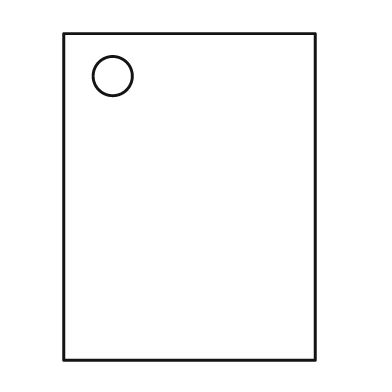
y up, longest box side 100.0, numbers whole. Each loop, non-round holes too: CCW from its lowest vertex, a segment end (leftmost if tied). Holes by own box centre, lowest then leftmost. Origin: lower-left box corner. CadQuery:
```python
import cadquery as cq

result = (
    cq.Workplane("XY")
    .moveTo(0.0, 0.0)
    .lineTo(77.0, 0.0)
    .lineTo(77.0, 100.0)
    .lineTo(0.0, 100.0)
    .close()
    .moveTo(15.0, 87.0)
    .circle(6.0)
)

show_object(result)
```